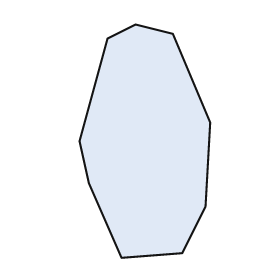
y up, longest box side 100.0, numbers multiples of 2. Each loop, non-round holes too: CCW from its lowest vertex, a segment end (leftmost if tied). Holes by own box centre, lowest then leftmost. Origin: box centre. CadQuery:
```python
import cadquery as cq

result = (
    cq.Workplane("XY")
    .moveTo(-10.0, -50.0)
    .lineTo(16.0, -48.0)
    .lineTo(26.0, -28.0)
    .lineTo(28.0, 8.0)
    .lineTo(12.0, 46.0)
    .lineTo(-4.0, 50.0)
    .lineTo(-16.0, 44.0)
    .lineTo(-28.0, 0.0)
    .lineTo(-24.0, -18.0)
    .close()
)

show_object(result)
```